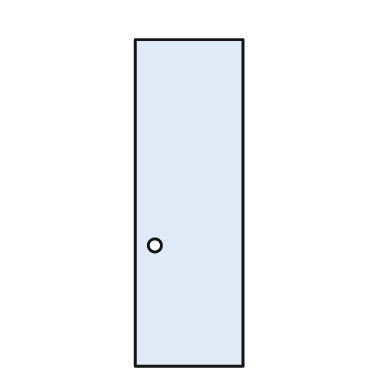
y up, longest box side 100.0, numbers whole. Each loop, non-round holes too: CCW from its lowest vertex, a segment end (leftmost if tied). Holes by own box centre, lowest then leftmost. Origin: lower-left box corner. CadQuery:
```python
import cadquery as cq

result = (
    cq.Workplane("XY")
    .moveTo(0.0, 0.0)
    .lineTo(33.0, 0.0)
    .lineTo(33.0, 100.0)
    .lineTo(0.0, 100.0)
    .close()
    .moveTo(6.0, 37.0)
    .circle(2.0)
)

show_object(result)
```